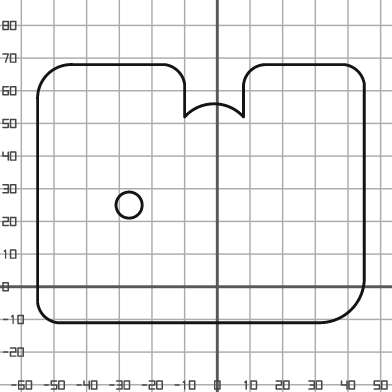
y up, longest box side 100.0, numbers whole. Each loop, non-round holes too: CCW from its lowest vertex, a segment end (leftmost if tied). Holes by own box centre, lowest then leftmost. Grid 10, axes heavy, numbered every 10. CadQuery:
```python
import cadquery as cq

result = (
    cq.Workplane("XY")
    .moveTo(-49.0, -11.0)
    .lineTo(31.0, -11.0)
    .threePointArc((41.0, -7.0), (45.0, 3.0))
    .lineTo(45.0, 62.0)
    .threePointArc((43.0, 66.0), (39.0, 68.0))
    .lineTo(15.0, 68.0)
    .threePointArc((10.0, 66.0), (8.0, 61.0))
    .lineTo(8.0, 52.0)
    .threePointArc((-1.0, 56.0), (-10.0, 52.0))
    .lineTo(-10.0, 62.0)
    .threePointArc((-12.0, 66.0), (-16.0, 68.0))
    .lineTo(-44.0, 68.0)
    .threePointArc((-52.0, 65.0), (-55.0, 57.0))
    .lineTo(-55.0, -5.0)
    .threePointArc((-53.0, -9.0), (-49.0, -11.0))
    .close()
    .moveTo(-27.0, 25.0)
    .circle(4.0)
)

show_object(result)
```